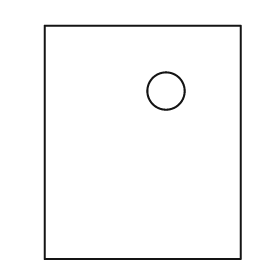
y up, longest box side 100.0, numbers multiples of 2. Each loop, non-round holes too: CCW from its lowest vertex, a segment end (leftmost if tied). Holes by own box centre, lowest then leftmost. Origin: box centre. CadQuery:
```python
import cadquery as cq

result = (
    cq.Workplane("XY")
    .moveTo(-42.0, -50.0)
    .lineTo(42.0, -50.0)
    .lineTo(42.0, 50.0)
    .lineTo(-42.0, 50.0)
    .close()
    .moveTo(10.0, 22.0)
    .circle(8.0)
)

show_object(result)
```